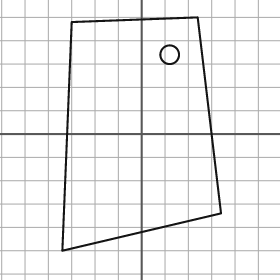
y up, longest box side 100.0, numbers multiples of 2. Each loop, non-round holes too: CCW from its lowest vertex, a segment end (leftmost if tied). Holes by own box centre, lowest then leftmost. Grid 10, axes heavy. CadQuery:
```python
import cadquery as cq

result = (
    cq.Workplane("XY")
    .moveTo(-34.0, -50.0)
    .lineTo(34.0, -34.0)
    .lineTo(24.0, 50.0)
    .lineTo(-30.0, 48.0)
    .close()
    .moveTo(12.0, 34.0)
    .circle(4.0)
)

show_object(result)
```